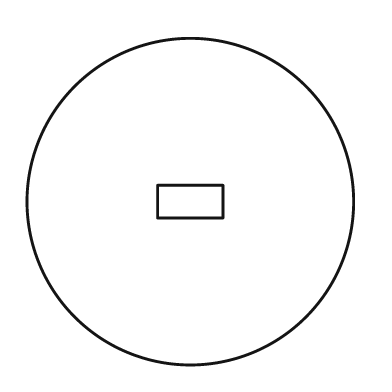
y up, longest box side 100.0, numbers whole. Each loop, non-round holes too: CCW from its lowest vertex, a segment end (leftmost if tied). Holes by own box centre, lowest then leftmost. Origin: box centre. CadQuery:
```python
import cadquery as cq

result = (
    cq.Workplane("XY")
    .moveTo(0.0, 0.0)
    .circle(50.0)
    .moveTo(-10.0, -5.0)
    .lineTo(10.0, -5.0)
    .lineTo(10.0, 5.0)
    .lineTo(-10.0, 5.0)
    .close()
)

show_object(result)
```